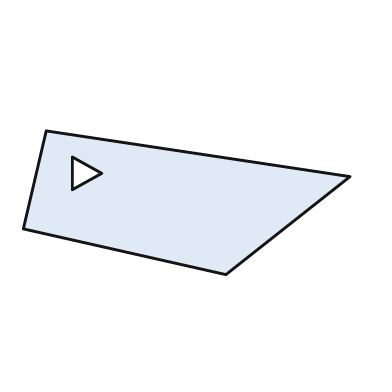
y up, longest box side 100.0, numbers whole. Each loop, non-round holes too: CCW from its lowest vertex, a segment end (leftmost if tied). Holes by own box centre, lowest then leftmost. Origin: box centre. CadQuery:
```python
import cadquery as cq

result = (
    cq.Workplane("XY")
    .moveTo(12.0, -22.0)
    .lineTo(50.0, 8.0)
    .lineTo(-43.0, 22.0)
    .lineTo(-50.0, -8.0)
    .close()
    .moveTo(-35.0, 4.0)
    .lineTo(-26.0, 9.0)
    .lineTo(-35.0, 14.0)
    .close()
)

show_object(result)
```